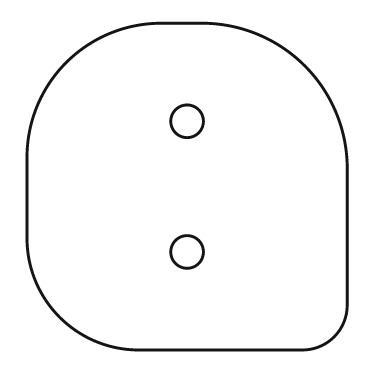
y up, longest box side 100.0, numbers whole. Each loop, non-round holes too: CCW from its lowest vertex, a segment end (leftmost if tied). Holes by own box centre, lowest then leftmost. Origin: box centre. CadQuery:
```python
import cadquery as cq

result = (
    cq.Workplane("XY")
    .moveTo(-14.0, -50.0)
    .lineTo(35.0, -50.0)
    .threePointArc((45.0, -46.0), (49.0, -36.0))
    .lineTo(49.0, 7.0)
    .threePointArc((36.0, 37.0), (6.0, 50.0))
    .lineTo(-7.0, 50.0)
    .threePointArc((-37.0, 38.0), (-49.0, 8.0))
    .lineTo(-49.0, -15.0)
    .threePointArc((-39.0, -40.0), (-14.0, -50.0))
    .close()
    .moveTo(0.0, -20.0)
    .circle(5.0)
    .moveTo(0.0, 20.0)
    .circle(5.0)
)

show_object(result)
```